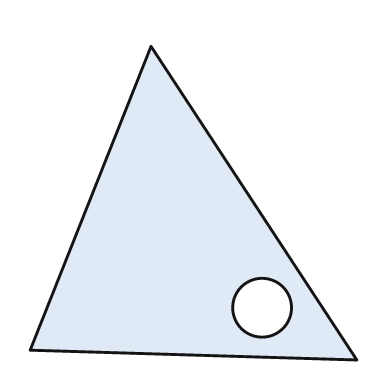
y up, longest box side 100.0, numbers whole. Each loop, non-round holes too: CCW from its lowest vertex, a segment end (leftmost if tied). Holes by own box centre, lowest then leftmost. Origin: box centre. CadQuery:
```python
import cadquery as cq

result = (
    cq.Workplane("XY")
    .moveTo(50.0, -48.0)
    .lineTo(-13.0, 48.0)
    .lineTo(-50.0, -45.0)
    .close()
    .moveTo(21.0, -32.0)
    .circle(9.0)
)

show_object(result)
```